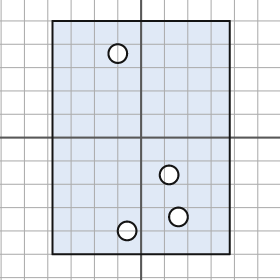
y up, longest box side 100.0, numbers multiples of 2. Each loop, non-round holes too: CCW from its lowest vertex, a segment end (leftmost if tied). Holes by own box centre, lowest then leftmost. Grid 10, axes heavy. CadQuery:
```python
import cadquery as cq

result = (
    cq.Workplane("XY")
    .moveTo(-38.0, -50.0)
    .lineTo(38.0, -50.0)
    .lineTo(38.0, 50.0)
    .lineTo(-38.0, 50.0)
    .close()
    .moveTo(-6.0, -40.0)
    .circle(4.0)
    .moveTo(16.0, -34.0)
    .circle(4.0)
    .moveTo(12.0, -16.0)
    .circle(4.0)
    .moveTo(-10.0, 36.0)
    .circle(4.0)
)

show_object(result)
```